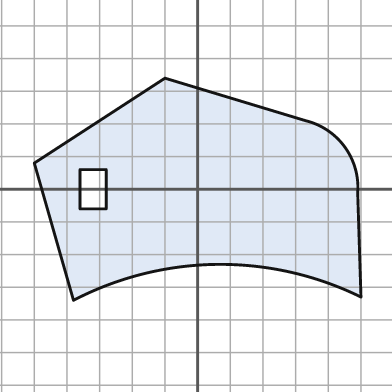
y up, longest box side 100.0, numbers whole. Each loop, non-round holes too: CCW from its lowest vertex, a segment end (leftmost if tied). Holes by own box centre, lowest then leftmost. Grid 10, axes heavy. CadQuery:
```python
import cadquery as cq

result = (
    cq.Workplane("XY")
    .moveTo(-38.0, -34.0)
    .threePointArc((6.0, -23.0), (50.0, -33.0))
    .lineTo(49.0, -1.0)
    .threePointArc((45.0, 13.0), (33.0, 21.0))
    .lineTo(-10.0, 34.0)
    .lineTo(-50.0, 8.0)
    .close()
    .moveTo(-36.0, -6.0)
    .lineTo(-28.0, -6.0)
    .lineTo(-28.0, 6.0)
    .lineTo(-36.0, 6.0)
    .close()
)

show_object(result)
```